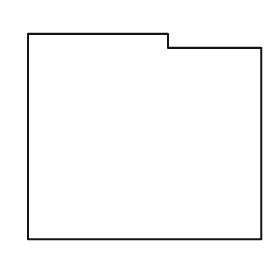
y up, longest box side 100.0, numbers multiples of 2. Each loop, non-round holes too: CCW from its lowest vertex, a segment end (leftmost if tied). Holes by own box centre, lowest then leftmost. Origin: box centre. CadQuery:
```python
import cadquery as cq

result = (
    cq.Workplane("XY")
    .moveTo(-50.0, -44.0)
    .lineTo(50.0, -44.0)
    .lineTo(50.0, 38.0)
    .lineTo(10.0, 38.0)
    .lineTo(10.0, 44.0)
    .lineTo(-50.0, 44.0)
    .close()
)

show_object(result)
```